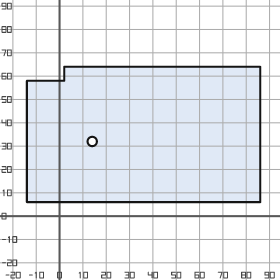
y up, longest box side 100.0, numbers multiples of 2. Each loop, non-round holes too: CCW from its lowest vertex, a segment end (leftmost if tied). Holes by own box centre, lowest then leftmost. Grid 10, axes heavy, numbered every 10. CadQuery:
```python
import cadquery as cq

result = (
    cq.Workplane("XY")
    .moveTo(-14.0, 6.0)
    .lineTo(86.0, 6.0)
    .lineTo(86.0, 64.0)
    .lineTo(2.0, 64.0)
    .lineTo(2.0, 58.0)
    .lineTo(-14.0, 58.0)
    .close()
    .moveTo(14.0, 32.0)
    .circle(2.0)
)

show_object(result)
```